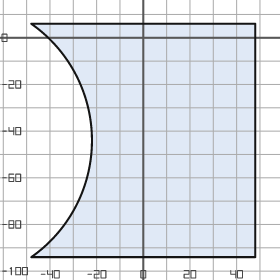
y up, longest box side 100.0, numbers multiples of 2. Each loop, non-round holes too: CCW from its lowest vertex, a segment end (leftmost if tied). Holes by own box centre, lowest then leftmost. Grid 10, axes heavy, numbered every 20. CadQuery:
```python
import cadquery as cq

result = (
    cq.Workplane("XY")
    .moveTo(-48.0, -94.0)
    .lineTo(48.0, -94.0)
    .lineTo(48.0, 6.0)
    .lineTo(-48.0, 6.0)
    .threePointArc((-22.0, -44.0), (-48.0, -94.0))
    .close()
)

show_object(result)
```